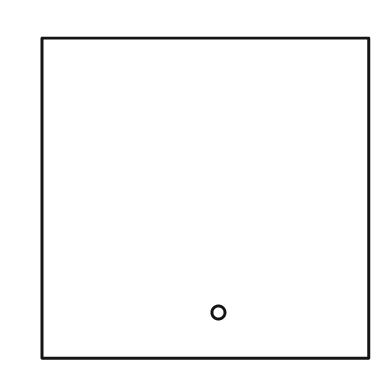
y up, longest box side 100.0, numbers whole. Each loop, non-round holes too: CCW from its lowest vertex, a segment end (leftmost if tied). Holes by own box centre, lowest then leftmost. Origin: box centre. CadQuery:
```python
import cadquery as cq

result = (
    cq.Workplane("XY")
    .moveTo(-50.0, -49.0)
    .lineTo(50.0, -49.0)
    .lineTo(50.0, 49.0)
    .lineTo(-50.0, 49.0)
    .close()
    .moveTo(4.0, -35.0)
    .circle(2.0)
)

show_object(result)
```